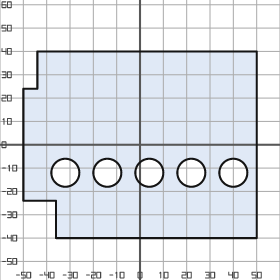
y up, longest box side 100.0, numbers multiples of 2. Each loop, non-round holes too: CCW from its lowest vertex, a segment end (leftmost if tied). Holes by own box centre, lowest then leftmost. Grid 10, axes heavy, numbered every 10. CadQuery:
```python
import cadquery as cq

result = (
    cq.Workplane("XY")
    .moveTo(-36.0, -40.0)
    .lineTo(50.0, -40.0)
    .lineTo(50.0, 40.0)
    .lineTo(-44.0, 40.0)
    .lineTo(-44.0, 24.0)
    .lineTo(-50.0, 24.0)
    .lineTo(-50.0, -24.0)
    .lineTo(-36.0, -24.0)
    .close()
    .moveTo(-32.0, -12.0)
    .circle(6.0)
    .moveTo(-14.0, -12.0)
    .circle(6.0)
    .moveTo(4.0, -12.0)
    .circle(6.0)
    .moveTo(22.0, -12.0)
    .circle(6.0)
    .moveTo(40.0, -12.0)
    .circle(6.0)
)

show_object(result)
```